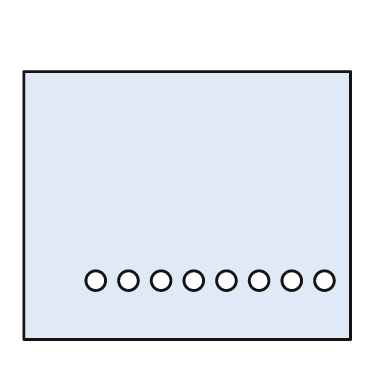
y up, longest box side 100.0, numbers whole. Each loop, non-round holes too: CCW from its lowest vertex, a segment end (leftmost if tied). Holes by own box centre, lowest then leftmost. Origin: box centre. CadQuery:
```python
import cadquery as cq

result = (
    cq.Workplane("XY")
    .moveTo(-50.0, -41.0)
    .lineTo(50.0, -41.0)
    .lineTo(50.0, 41.0)
    .lineTo(-50.0, 41.0)
    .close()
    .moveTo(-28.0, -23.0)
    .circle(3.0)
    .moveTo(-18.0, -23.0)
    .circle(3.0)
    .moveTo(-8.0, -23.0)
    .circle(3.0)
    .moveTo(2.0, -23.0)
    .circle(3.0)
    .moveTo(12.0, -23.0)
    .circle(3.0)
    .moveTo(22.0, -23.0)
    .circle(3.0)
    .moveTo(32.0, -23.0)
    .circle(3.0)
    .moveTo(42.0, -23.0)
    .circle(3.0)
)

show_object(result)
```